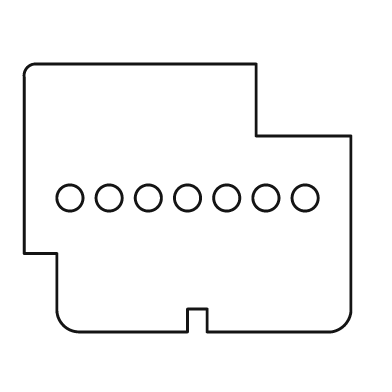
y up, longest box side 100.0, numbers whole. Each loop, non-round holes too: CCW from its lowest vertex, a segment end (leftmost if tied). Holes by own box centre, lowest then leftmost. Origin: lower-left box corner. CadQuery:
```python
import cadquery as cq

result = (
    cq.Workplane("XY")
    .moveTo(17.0, 0.0)
    .lineTo(50.0, 0.0)
    .lineTo(50.0, 7.0)
    .lineTo(56.0, 7.0)
    .lineTo(56.0, 0.0)
    .lineTo(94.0, 0.0)
    .threePointArc((98.0, 2.0), (100.0, 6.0))
    .lineTo(100.0, 60.0)
    .lineTo(71.0, 60.0)
    .lineTo(71.0, 82.0)
    .lineTo(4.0, 82.0)
    .threePointArc((1.0, 81.0), (0.0, 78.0))
    .lineTo(0.0, 24.0)
    .lineTo(10.0, 24.0)
    .lineTo(10.0, 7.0)
    .threePointArc((12.0, 2.0), (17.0, 0.0))
    .close()
    .moveTo(14.0, 41.0)
    .circle(4.0)
    .moveTo(26.0, 41.0)
    .circle(4.0)
    .moveTo(38.0, 41.0)
    .circle(4.0)
    .moveTo(50.0, 41.0)
    .circle(4.0)
    .moveTo(62.0, 41.0)
    .circle(4.0)
    .moveTo(74.0, 41.0)
    .circle(4.0)
    .moveTo(86.0, 41.0)
    .circle(4.0)
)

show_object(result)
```